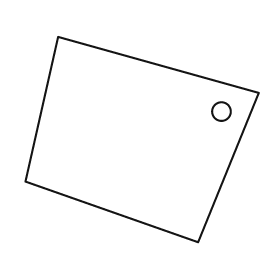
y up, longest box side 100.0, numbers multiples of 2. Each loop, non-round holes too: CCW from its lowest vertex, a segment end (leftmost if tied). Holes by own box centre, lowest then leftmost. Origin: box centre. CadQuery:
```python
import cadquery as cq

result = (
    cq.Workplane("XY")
    .moveTo(24.0, -44.0)
    .lineTo(50.0, 20.0)
    .lineTo(-36.0, 44.0)
    .lineTo(-50.0, -18.0)
    .close()
    .moveTo(34.0, 12.0)
    .circle(4.0)
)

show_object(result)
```